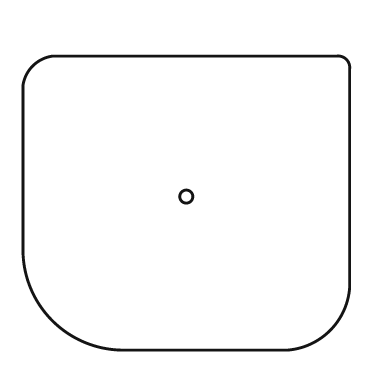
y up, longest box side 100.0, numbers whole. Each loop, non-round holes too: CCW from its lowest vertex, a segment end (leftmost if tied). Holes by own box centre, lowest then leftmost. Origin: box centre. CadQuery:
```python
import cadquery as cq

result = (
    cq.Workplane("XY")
    .moveTo(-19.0, -45.0)
    .lineTo(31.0, -45.0)
    .threePointArc((44.0, -39.0), (50.0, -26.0))
    .lineTo(50.0, 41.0)
    .threePointArc((49.0, 44.0), (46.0, 45.0))
    .lineTo(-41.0, 45.0)
    .threePointArc((-47.0, 42.0), (-50.0, 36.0))
    .lineTo(-50.0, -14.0)
    .threePointArc((-41.0, -36.0), (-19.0, -45.0))
    .close()
    .moveTo(0.0, 2.0)
    .circle(2.0)
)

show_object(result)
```